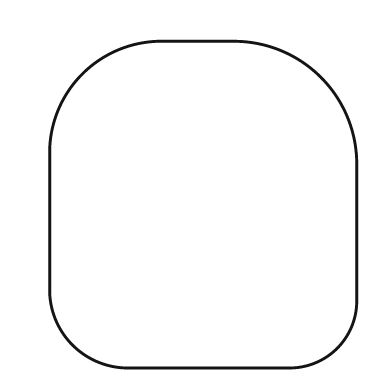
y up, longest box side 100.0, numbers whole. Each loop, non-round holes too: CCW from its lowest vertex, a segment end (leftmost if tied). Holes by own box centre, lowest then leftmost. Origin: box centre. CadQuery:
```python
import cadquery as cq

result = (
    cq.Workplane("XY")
    .moveTo(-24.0, -50.0)
    .lineTo(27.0, -50.0)
    .threePointArc((41.0, -44.0), (47.0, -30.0))
    .lineTo(47.0, 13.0)
    .threePointArc((36.0, 39.0), (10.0, 50.0))
    .lineTo(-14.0, 50.0)
    .threePointArc((-37.0, 40.0), (-47.0, 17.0))
    .lineTo(-47.0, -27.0)
    .threePointArc((-40.0, -43.0), (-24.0, -50.0))
    .close()
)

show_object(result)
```